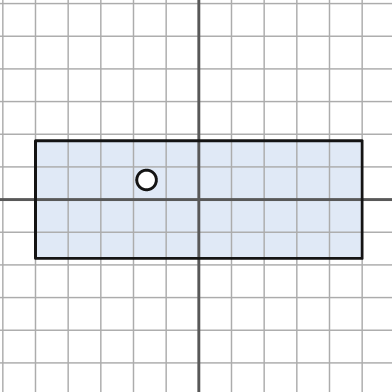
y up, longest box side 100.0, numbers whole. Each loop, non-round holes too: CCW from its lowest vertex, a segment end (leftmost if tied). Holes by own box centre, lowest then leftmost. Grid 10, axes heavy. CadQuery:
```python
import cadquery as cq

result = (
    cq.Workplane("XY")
    .moveTo(-50.0, -18.0)
    .lineTo(50.0, -18.0)
    .lineTo(50.0, 18.0)
    .lineTo(-50.0, 18.0)
    .close()
    .moveTo(-16.0, 6.0)
    .circle(3.0)
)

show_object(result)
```